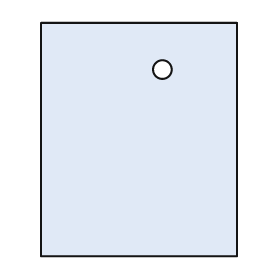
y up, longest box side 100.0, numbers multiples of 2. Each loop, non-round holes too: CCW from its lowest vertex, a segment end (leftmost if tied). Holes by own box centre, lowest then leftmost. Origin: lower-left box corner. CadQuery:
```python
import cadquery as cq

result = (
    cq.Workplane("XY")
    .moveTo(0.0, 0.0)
    .lineTo(84.0, 0.0)
    .lineTo(84.0, 100.0)
    .lineTo(0.0, 100.0)
    .close()
    .moveTo(52.0, 80.0)
    .circle(4.0)
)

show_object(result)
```